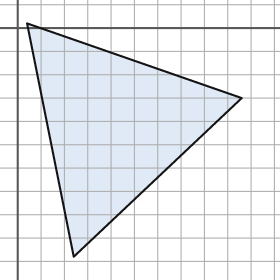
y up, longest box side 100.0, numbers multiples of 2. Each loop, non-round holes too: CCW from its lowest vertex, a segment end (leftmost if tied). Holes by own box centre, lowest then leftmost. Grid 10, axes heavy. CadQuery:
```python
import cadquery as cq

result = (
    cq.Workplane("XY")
    .moveTo(24.0, -98.0)
    .lineTo(96.0, -30.0)
    .lineTo(4.0, 2.0)
    .close()
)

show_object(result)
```